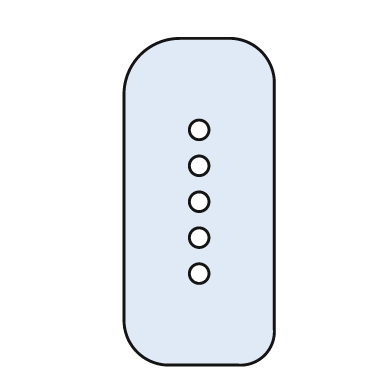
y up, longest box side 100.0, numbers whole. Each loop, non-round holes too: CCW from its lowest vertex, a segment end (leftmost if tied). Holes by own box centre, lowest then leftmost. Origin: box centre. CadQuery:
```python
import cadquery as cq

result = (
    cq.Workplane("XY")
    .moveTo(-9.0, -50.0)
    .lineTo(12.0, -50.0)
    .threePointArc((20.0, -47.0), (23.0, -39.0))
    .lineTo(23.0, 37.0)
    .threePointArc((19.0, 46.0), (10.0, 50.0))
    .lineTo(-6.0, 50.0)
    .threePointArc((-18.0, 45.0), (-23.0, 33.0))
    .lineTo(-23.0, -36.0)
    .threePointArc((-19.0, -46.0), (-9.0, -50.0))
    .close()
    .moveTo(0.0, -22.0)
    .circle(3.0)
    .moveTo(0.0, -11.0)
    .circle(3.0)
    .moveTo(0.0, 0.0)
    .circle(3.0)
    .moveTo(0.0, 11.0)
    .circle(3.0)
    .moveTo(0.0, 22.0)
    .circle(3.0)
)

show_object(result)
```